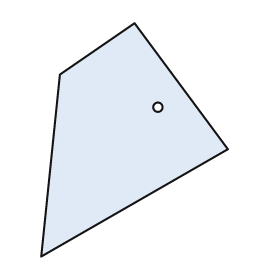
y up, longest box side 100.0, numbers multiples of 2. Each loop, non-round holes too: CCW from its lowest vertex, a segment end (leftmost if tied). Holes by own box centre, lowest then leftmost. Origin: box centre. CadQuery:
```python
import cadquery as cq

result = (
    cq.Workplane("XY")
    .moveTo(-40.0, -50.0)
    .lineTo(40.0, -4.0)
    .lineTo(0.0, 50.0)
    .lineTo(-32.0, 28.0)
    .close()
    .moveTo(10.0, 14.0)
    .circle(2.0)
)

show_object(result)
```